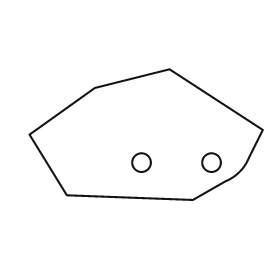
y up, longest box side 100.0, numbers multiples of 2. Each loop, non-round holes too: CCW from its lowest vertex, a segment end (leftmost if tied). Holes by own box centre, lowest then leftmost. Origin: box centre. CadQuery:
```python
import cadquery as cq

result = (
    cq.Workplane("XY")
    .moveTo(20.0, -28.0)
    .lineTo(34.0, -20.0)
    .threePointArc((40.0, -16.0), (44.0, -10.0))
    .lineTo(50.0, 2.0)
    .lineTo(10.0, 28.0)
    .lineTo(-22.0, 20.0)
    .lineTo(-50.0, 0.0)
    .lineTo(-34.0, -26.0)
    .close()
    .moveTo(-2.0, -12.0)
    .circle(4.0)
    .moveTo(28.0, -12.0)
    .circle(4.0)
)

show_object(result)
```